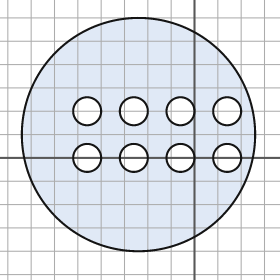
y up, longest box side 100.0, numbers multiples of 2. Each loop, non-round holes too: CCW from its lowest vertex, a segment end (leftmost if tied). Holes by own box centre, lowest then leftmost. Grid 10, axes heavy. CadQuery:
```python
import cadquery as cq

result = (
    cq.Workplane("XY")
    .moveTo(-24.0, 10.0)
    .circle(50.0)
    .moveTo(-46.0, 0.0)
    .circle(6.0)
    .moveTo(-26.0, 0.0)
    .circle(6.0)
    .moveTo(-6.0, 0.0)
    .circle(6.0)
    .moveTo(14.0, 0.0)
    .circle(6.0)
    .moveTo(-46.0, 20.0)
    .circle(6.0)
    .moveTo(-26.0, 20.0)
    .circle(6.0)
    .moveTo(-6.0, 20.0)
    .circle(6.0)
    .moveTo(14.0, 20.0)
    .circle(6.0)
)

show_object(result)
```